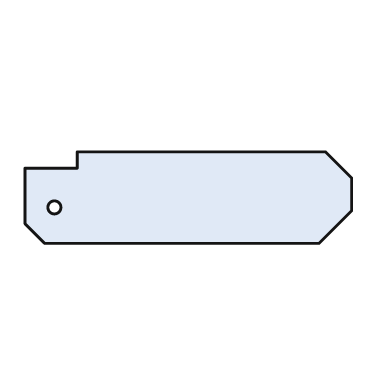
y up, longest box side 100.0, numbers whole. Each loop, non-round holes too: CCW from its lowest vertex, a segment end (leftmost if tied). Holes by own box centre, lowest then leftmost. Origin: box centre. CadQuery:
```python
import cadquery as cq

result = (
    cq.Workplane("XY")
    .moveTo(-44.0, -14.0)
    .lineTo(40.0, -14.0)
    .lineTo(50.0, -4.0)
    .lineTo(50.0, 6.0)
    .lineTo(42.0, 14.0)
    .lineTo(-34.0, 14.0)
    .lineTo(-34.0, 9.0)
    .lineTo(-50.0, 9.0)
    .lineTo(-50.0, -8.0)
    .close()
    .moveTo(-41.0, -3.0)
    .circle(2.0)
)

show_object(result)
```